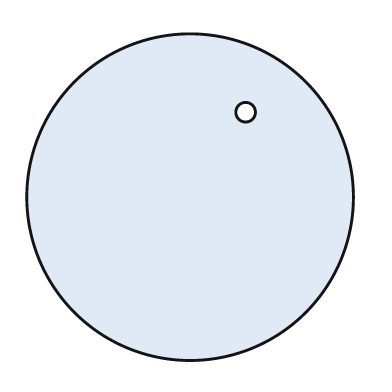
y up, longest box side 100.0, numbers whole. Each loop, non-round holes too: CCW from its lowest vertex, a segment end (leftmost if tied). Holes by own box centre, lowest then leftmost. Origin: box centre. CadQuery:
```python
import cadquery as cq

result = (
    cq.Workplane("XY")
    .moveTo(0.0, 0.0)
    .circle(50.0)
    .moveTo(17.0, 26.0)
    .circle(3.0)
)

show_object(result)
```